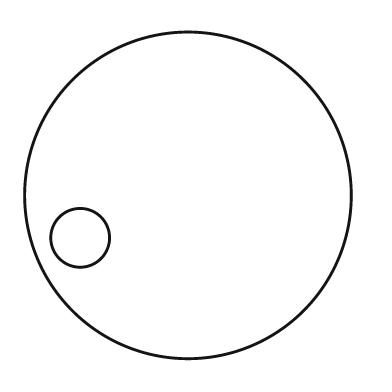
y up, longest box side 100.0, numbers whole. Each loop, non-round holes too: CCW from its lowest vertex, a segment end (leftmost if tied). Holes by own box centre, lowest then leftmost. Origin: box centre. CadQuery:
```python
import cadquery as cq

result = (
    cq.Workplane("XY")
    .moveTo(0.0, 0.0)
    .circle(50.0)
    .moveTo(-33.0, -13.0)
    .circle(9.0)
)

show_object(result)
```